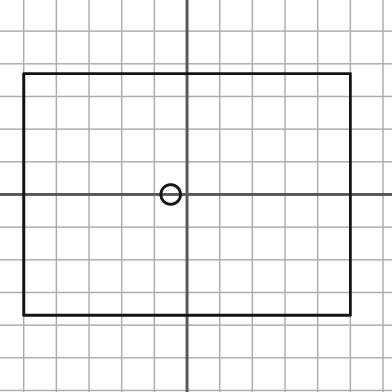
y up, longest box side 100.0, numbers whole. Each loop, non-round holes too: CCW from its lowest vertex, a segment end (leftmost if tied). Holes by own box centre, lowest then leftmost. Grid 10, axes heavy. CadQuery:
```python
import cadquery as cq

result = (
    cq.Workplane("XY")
    .moveTo(-50.0, -37.0)
    .lineTo(50.0, -37.0)
    .lineTo(50.0, 37.0)
    .lineTo(-50.0, 37.0)
    .close()
    .moveTo(-5.0, 0.0)
    .circle(3.0)
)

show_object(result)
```